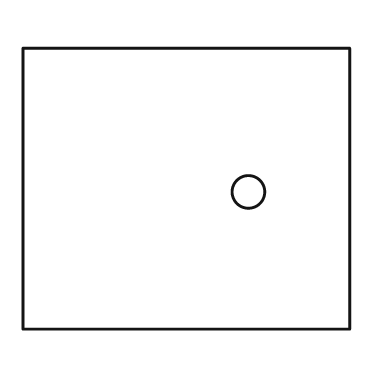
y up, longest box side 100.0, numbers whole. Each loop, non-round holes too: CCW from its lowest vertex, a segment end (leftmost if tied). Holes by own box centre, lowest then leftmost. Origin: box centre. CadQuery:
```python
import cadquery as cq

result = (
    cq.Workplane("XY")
    .moveTo(-50.0, -43.0)
    .lineTo(50.0, -43.0)
    .lineTo(50.0, 43.0)
    .lineTo(-50.0, 43.0)
    .close()
    .moveTo(19.0, -1.0)
    .circle(5.0)
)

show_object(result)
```